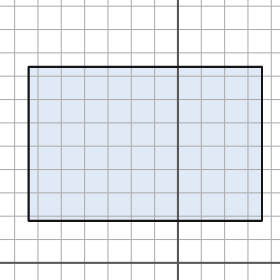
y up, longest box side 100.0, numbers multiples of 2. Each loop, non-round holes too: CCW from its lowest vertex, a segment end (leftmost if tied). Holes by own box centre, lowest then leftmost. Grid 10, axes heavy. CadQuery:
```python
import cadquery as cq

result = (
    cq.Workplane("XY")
    .moveTo(-64.0, 18.0)
    .lineTo(36.0, 18.0)
    .lineTo(36.0, 84.0)
    .lineTo(-64.0, 84.0)
    .close()
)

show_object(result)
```